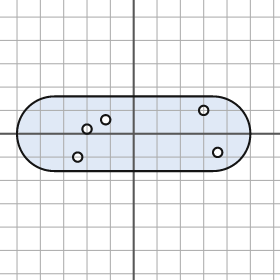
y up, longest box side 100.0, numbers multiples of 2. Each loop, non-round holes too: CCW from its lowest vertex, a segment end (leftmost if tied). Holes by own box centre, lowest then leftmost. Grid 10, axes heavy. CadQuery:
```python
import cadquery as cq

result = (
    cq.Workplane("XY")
    .moveTo(-34.0, -16.0)
    .lineTo(34.0, -16.0)
    .threePointArc((50.0, 0.0), (34.0, 16.0))
    .lineTo(-34.0, 16.0)
    .threePointArc((-50.0, 0.0), (-34.0, -16.0))
    .close()
    .moveTo(-24.0, -10.0)
    .circle(2.0)
    .moveTo(36.0, -8.0)
    .circle(2.0)
    .moveTo(-20.0, 2.0)
    .circle(2.0)
    .moveTo(-12.0, 6.0)
    .circle(2.0)
    .moveTo(30.0, 10.0)
    .circle(2.0)
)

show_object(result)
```